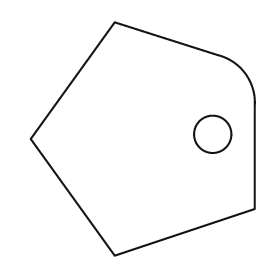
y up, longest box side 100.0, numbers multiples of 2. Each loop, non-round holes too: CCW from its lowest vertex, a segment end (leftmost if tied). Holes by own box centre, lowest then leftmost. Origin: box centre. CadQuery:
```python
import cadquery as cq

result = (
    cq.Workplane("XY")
    .moveTo(-12.0, -50.0)
    .lineTo(48.0, -30.0)
    .lineTo(48.0, 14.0)
    .threePointArc((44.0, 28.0), (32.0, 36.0))
    .lineTo(-12.0, 50.0)
    .lineTo(-48.0, 0.0)
    .close()
    .moveTo(30.0, 2.0)
    .circle(8.0)
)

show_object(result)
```